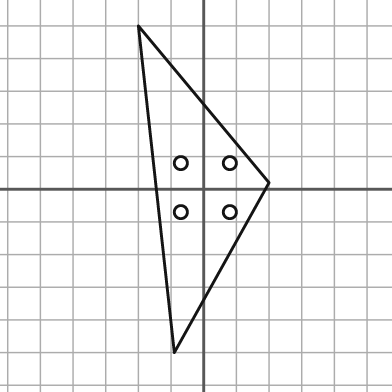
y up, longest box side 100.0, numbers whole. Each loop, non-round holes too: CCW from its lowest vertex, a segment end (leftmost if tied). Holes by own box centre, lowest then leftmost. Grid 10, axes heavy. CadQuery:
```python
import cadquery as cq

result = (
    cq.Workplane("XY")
    .moveTo(-9.0, -50.0)
    .lineTo(20.0, 2.0)
    .lineTo(-20.0, 50.0)
    .close()
    .moveTo(-7.0, -7.0)
    .circle(2.0)
    .moveTo(8.0, -7.0)
    .circle(2.0)
    .moveTo(-7.0, 8.0)
    .circle(2.0)
    .moveTo(8.0, 8.0)
    .circle(2.0)
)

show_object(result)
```